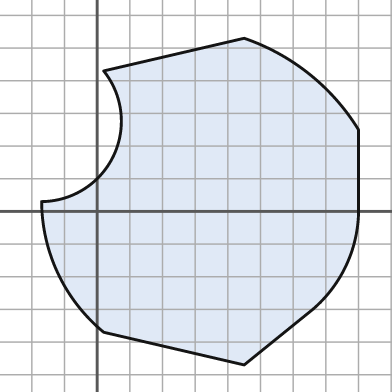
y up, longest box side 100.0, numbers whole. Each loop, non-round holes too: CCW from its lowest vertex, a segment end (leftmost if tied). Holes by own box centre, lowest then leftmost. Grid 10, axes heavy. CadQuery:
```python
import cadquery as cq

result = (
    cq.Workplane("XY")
    .moveTo(45.0, -47.0)
    .lineTo(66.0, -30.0)
    .threePointArc((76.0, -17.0), (80.0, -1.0))
    .lineTo(80.0, 25.0)
    .threePointArc((65.0, 42.0), (45.0, 53.0))
    .lineTo(2.0, 43.0)
    .threePointArc((5.0, 17.0), (-17.0, 3.0))
    .threePointArc((-12.0, -19.0), (2.0, -37.0))
    .close()
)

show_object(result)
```